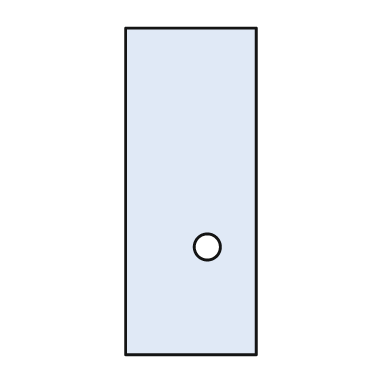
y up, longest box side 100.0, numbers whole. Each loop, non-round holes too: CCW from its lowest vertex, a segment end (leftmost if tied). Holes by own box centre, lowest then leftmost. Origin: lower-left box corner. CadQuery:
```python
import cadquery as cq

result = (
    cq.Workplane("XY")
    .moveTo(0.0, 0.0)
    .lineTo(40.0, 0.0)
    .lineTo(40.0, 100.0)
    .lineTo(0.0, 100.0)
    .close()
    .moveTo(25.0, 33.0)
    .circle(4.0)
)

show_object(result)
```